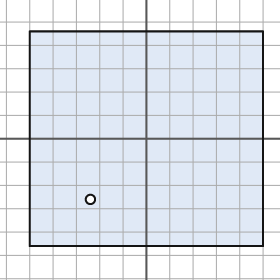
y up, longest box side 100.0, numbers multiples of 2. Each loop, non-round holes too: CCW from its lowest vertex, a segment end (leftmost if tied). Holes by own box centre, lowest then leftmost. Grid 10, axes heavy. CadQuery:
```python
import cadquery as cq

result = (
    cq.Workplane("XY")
    .moveTo(-50.0, -46.0)
    .lineTo(50.0, -46.0)
    .lineTo(50.0, 46.0)
    .lineTo(-50.0, 46.0)
    .close()
    .moveTo(-24.0, -26.0)
    .circle(2.0)
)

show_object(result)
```